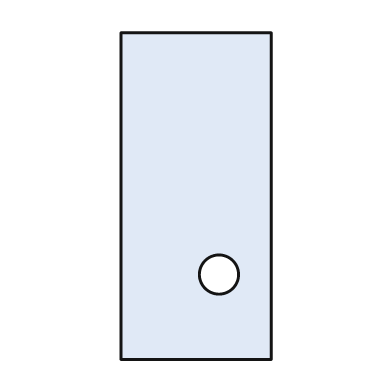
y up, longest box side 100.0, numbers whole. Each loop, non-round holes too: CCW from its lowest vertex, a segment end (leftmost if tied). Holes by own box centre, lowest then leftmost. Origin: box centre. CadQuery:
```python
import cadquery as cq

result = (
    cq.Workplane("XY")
    .moveTo(-23.0, -50.0)
    .lineTo(23.0, -50.0)
    .lineTo(23.0, 50.0)
    .lineTo(-23.0, 50.0)
    .close()
    .moveTo(7.0, -24.0)
    .circle(6.0)
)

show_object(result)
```